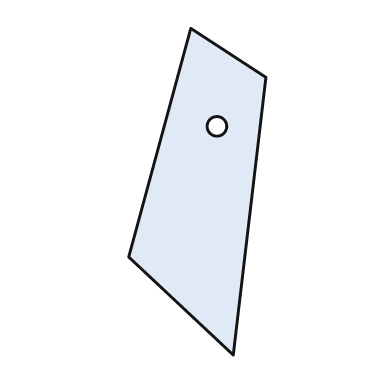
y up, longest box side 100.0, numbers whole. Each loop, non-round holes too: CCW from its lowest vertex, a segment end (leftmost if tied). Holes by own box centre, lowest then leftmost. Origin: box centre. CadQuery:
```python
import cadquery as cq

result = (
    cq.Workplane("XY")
    .moveTo(11.0, -50.0)
    .lineTo(21.0, 35.0)
    .lineTo(-2.0, 50.0)
    .lineTo(-21.0, -20.0)
    .close()
    .moveTo(6.0, 20.0)
    .circle(3.0)
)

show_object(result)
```